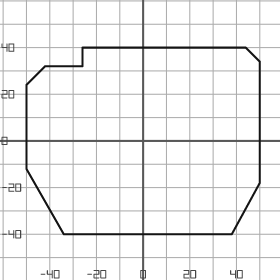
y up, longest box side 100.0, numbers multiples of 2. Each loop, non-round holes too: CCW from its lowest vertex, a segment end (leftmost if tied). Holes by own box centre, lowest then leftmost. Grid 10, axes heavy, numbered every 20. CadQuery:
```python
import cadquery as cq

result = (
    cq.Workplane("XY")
    .moveTo(-34.0, -40.0)
    .lineTo(38.0, -40.0)
    .lineTo(50.0, -18.0)
    .lineTo(50.0, 34.0)
    .lineTo(44.0, 40.0)
    .lineTo(-26.0, 40.0)
    .lineTo(-26.0, 32.0)
    .lineTo(-42.0, 32.0)
    .lineTo(-50.0, 24.0)
    .lineTo(-50.0, -12.0)
    .close()
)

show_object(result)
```